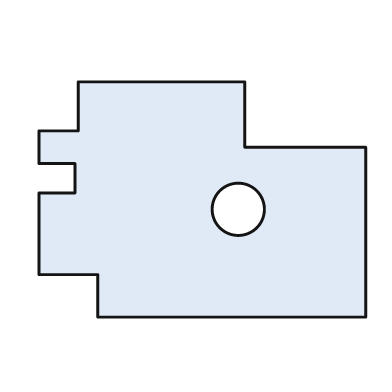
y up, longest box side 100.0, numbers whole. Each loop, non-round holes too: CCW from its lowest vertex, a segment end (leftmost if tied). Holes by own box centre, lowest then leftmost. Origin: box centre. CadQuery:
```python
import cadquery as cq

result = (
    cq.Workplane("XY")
    .moveTo(-32.0, -36.0)
    .lineTo(50.0, -36.0)
    .lineTo(50.0, 16.0)
    .lineTo(13.0, 16.0)
    .lineTo(13.0, 36.0)
    .lineTo(-38.0, 36.0)
    .lineTo(-38.0, 21.0)
    .lineTo(-50.0, 21.0)
    .lineTo(-50.0, 11.0)
    .lineTo(-39.0, 11.0)
    .lineTo(-39.0, 2.0)
    .lineTo(-50.0, 2.0)
    .lineTo(-50.0, -23.0)
    .lineTo(-32.0, -23.0)
    .close()
    .moveTo(11.0, -3.0)
    .circle(8.0)
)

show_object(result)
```